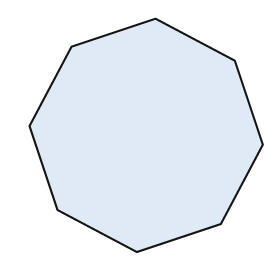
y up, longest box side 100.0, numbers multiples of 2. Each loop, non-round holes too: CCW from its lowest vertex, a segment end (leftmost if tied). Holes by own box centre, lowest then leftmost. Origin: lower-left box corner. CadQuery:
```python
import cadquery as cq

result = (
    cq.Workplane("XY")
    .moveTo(46.0, 0.0)
    .lineTo(82.0, 12.0)
    .lineTo(100.0, 46.0)
    .lineTo(88.0, 82.0)
    .lineTo(54.0, 100.0)
    .lineTo(18.0, 88.0)
    .lineTo(0.0, 54.0)
    .lineTo(12.0, 18.0)
    .close()
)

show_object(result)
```